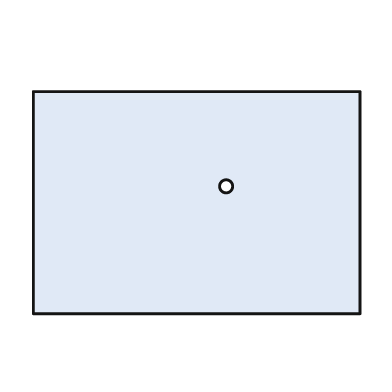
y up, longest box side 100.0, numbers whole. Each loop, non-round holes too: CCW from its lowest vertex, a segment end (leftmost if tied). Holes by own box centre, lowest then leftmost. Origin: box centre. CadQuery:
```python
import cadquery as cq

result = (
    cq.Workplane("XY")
    .moveTo(-50.0, -34.0)
    .lineTo(50.0, -34.0)
    .lineTo(50.0, 34.0)
    .lineTo(-50.0, 34.0)
    .close()
    .moveTo(9.0, 5.0)
    .circle(2.0)
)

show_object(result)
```